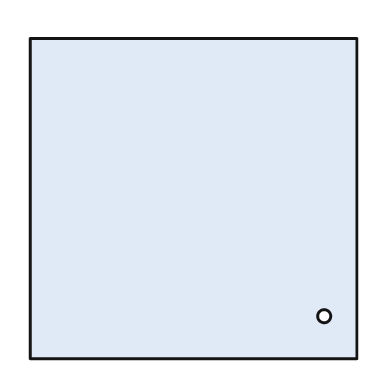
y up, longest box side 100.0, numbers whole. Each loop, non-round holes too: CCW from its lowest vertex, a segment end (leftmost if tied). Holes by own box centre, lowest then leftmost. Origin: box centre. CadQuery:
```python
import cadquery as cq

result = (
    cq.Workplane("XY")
    .moveTo(-50.0, -49.0)
    .lineTo(50.0, -49.0)
    .lineTo(50.0, 49.0)
    .lineTo(-50.0, 49.0)
    .close()
    .moveTo(40.0, -36.0)
    .circle(2.0)
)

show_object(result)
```